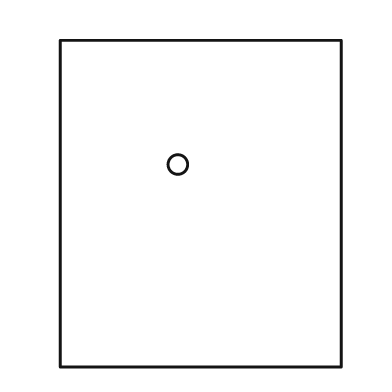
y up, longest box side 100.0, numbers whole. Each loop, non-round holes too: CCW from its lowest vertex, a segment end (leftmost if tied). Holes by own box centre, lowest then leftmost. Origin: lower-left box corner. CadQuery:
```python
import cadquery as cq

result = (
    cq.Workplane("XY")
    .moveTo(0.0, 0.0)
    .lineTo(86.0, 0.0)
    .lineTo(86.0, 100.0)
    .lineTo(0.0, 100.0)
    .close()
    .moveTo(36.0, 62.0)
    .circle(3.0)
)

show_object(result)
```